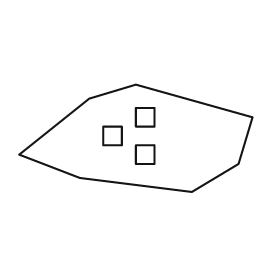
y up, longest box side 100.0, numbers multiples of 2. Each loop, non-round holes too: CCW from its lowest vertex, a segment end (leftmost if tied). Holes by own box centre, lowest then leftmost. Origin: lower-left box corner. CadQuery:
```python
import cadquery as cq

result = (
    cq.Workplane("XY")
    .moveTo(74.0, 0.0)
    .lineTo(94.0, 12.0)
    .lineTo(100.0, 32.0)
    .lineTo(50.0, 46.0)
    .lineTo(30.0, 40.0)
    .lineTo(0.0, 16.0)
    .lineTo(26.0, 6.0)
    .close()
    .moveTo(50.0, 12.0)
    .lineTo(58.0, 12.0)
    .lineTo(58.0, 20.0)
    .lineTo(50.0, 20.0)
    .close()
    .moveTo(36.0, 20.0)
    .lineTo(44.0, 20.0)
    .lineTo(44.0, 28.0)
    .lineTo(36.0, 28.0)
    .close()
    .moveTo(50.0, 28.0)
    .lineTo(58.0, 28.0)
    .lineTo(58.0, 36.0)
    .lineTo(50.0, 36.0)
    .close()
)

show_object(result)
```